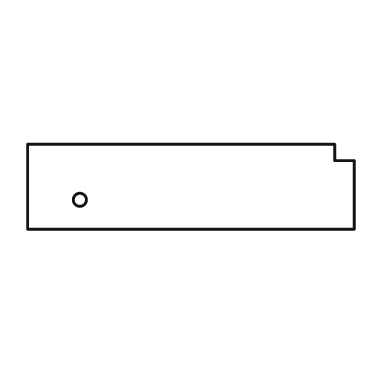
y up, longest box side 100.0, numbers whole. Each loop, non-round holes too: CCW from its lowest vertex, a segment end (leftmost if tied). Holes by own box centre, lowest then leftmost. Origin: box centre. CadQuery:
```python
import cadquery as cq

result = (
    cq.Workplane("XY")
    .moveTo(-50.0, -13.0)
    .lineTo(50.0, -13.0)
    .lineTo(50.0, 8.0)
    .lineTo(44.0, 8.0)
    .lineTo(44.0, 13.0)
    .lineTo(-50.0, 13.0)
    .close()
    .moveTo(-34.0, -4.0)
    .circle(2.0)
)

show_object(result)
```